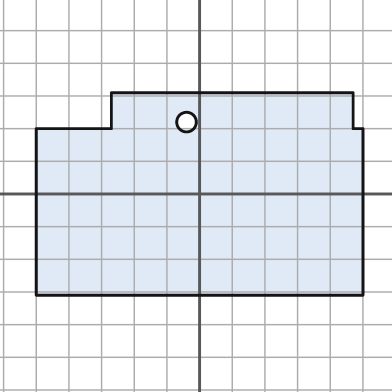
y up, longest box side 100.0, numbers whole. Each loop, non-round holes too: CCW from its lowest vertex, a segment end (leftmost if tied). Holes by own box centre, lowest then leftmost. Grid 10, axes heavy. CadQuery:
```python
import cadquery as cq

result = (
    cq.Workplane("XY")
    .moveTo(-50.0, -31.0)
    .lineTo(50.0, -31.0)
    .lineTo(50.0, 20.0)
    .lineTo(47.0, 20.0)
    .lineTo(47.0, 31.0)
    .lineTo(-27.0, 31.0)
    .lineTo(-27.0, 20.0)
    .lineTo(-50.0, 20.0)
    .close()
    .moveTo(-4.0, 22.0)
    .circle(3.0)
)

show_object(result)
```